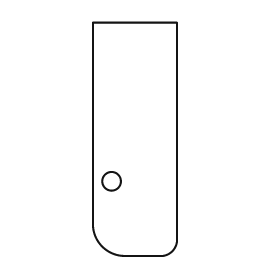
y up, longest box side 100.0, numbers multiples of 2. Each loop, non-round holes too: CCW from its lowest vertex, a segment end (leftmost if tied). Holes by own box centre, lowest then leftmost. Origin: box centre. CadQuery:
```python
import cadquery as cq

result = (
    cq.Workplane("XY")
    .moveTo(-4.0, -50.0)
    .lineTo(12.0, -50.0)
    .threePointArc((16.0, -48.0), (18.0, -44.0))
    .lineTo(18.0, 50.0)
    .lineTo(-18.0, 50.0)
    .lineTo(-18.0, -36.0)
    .threePointArc((-14.0, -46.0), (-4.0, -50.0))
    .close()
    .moveTo(-10.0, -18.0)
    .circle(4.0)
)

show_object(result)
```